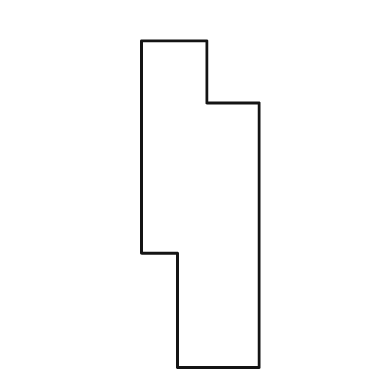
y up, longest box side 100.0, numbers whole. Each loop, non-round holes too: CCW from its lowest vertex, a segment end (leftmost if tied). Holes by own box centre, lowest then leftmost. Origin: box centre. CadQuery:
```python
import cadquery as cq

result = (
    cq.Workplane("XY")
    .moveTo(-7.0, -50.0)
    .lineTo(18.0, -50.0)
    .lineTo(18.0, 31.0)
    .lineTo(2.0, 31.0)
    .lineTo(2.0, 50.0)
    .lineTo(-18.0, 50.0)
    .lineTo(-18.0, -15.0)
    .lineTo(-7.0, -15.0)
    .close()
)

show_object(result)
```